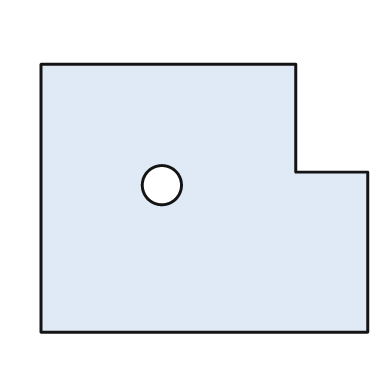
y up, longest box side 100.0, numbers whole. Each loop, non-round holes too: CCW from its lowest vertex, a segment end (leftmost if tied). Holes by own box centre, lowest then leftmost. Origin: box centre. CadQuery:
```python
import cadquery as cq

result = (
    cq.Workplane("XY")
    .moveTo(-50.0, -41.0)
    .lineTo(50.0, -41.0)
    .lineTo(50.0, 8.0)
    .lineTo(28.0, 8.0)
    .lineTo(28.0, 41.0)
    .lineTo(-50.0, 41.0)
    .close()
    .moveTo(-13.0, 4.0)
    .circle(6.0)
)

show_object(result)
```